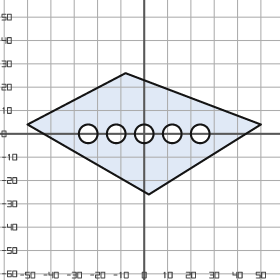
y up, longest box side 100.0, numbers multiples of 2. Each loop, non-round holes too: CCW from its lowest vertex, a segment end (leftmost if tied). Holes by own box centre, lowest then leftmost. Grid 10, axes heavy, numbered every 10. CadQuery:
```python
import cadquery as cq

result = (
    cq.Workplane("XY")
    .moveTo(2.0, -26.0)
    .lineTo(50.0, 4.0)
    .lineTo(-8.0, 26.0)
    .lineTo(-50.0, 4.0)
    .close()
    .moveTo(-24.0, 0.0)
    .circle(4.0)
    .moveTo(-12.0, 0.0)
    .circle(4.0)
    .moveTo(0.0, 0.0)
    .circle(4.0)
    .moveTo(12.0, 0.0)
    .circle(4.0)
    .moveTo(24.0, 0.0)
    .circle(4.0)
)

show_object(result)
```